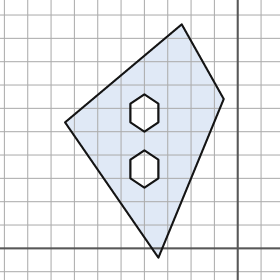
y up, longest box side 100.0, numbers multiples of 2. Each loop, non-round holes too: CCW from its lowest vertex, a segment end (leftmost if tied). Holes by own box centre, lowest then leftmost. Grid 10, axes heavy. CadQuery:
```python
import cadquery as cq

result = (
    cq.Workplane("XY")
    .moveTo(-34.0, -4.0)
    .lineTo(-6.0, 64.0)
    .lineTo(-24.0, 96.0)
    .lineTo(-74.0, 54.0)
    .close()
    .moveTo(-40.0, 26.0)
    .lineTo(-34.0, 30.0)
    .lineTo(-34.0, 38.0)
    .lineTo(-40.0, 42.0)
    .lineTo(-46.0, 38.0)
    .lineTo(-46.0, 30.0)
    .close()
    .moveTo(-40.0, 50.0)
    .lineTo(-34.0, 54.0)
    .lineTo(-34.0, 62.0)
    .lineTo(-40.0, 66.0)
    .lineTo(-46.0, 62.0)
    .lineTo(-46.0, 54.0)
    .close()
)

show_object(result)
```